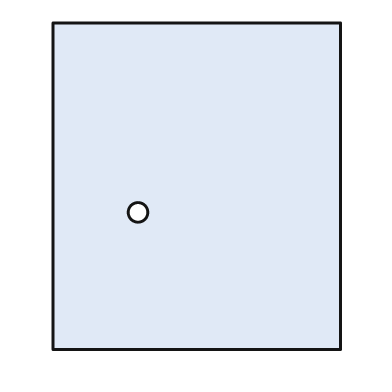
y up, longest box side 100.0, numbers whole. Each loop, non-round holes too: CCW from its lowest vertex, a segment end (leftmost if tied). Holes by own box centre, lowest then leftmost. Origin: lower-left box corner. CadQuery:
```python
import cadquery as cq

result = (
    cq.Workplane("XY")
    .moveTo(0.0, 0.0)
    .lineTo(88.0, 0.0)
    .lineTo(88.0, 100.0)
    .lineTo(0.0, 100.0)
    .close()
    .moveTo(26.0, 42.0)
    .circle(3.0)
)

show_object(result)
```